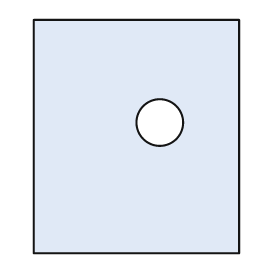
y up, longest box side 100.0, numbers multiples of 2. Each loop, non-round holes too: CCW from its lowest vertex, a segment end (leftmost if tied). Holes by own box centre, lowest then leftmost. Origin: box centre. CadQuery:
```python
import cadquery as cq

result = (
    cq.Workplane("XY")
    .moveTo(-44.0, -50.0)
    .lineTo(44.0, -50.0)
    .lineTo(44.0, 50.0)
    .lineTo(-44.0, 50.0)
    .close()
    .moveTo(10.0, 6.0)
    .circle(10.0)
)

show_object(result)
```